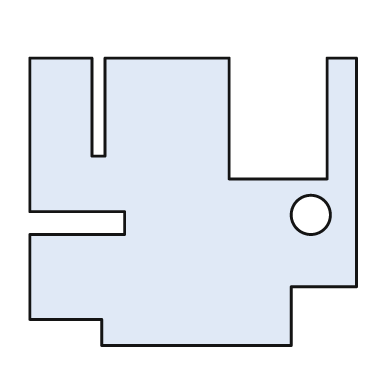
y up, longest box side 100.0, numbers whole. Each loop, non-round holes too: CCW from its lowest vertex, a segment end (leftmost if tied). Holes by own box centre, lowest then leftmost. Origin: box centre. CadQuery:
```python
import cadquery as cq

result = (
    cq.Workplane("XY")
    .moveTo(-28.0, -44.0)
    .lineTo(30.0, -44.0)
    .lineTo(30.0, -26.0)
    .lineTo(50.0, -26.0)
    .lineTo(50.0, 44.0)
    .lineTo(41.0, 44.0)
    .lineTo(41.0, 7.0)
    .lineTo(11.0, 7.0)
    .lineTo(11.0, 44.0)
    .lineTo(-27.0, 44.0)
    .lineTo(-27.0, 14.0)
    .lineTo(-31.0, 14.0)
    .lineTo(-31.0, 44.0)
    .lineTo(-50.0, 44.0)
    .lineTo(-50.0, -3.0)
    .lineTo(-21.0, -3.0)
    .lineTo(-21.0, -10.0)
    .lineTo(-50.0, -10.0)
    .lineTo(-50.0, -36.0)
    .lineTo(-28.0, -36.0)
    .close()
    .moveTo(36.0, -4.0)
    .circle(6.0)
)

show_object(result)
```